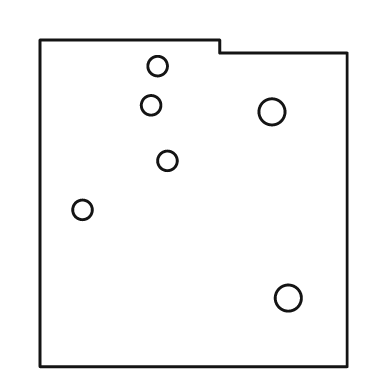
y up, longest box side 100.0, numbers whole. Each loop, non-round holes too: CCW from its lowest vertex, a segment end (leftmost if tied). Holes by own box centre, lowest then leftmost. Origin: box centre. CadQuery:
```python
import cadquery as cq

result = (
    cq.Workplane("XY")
    .moveTo(-47.0, -50.0)
    .lineTo(47.0, -50.0)
    .lineTo(47.0, 46.0)
    .lineTo(8.0, 46.0)
    .lineTo(8.0, 50.0)
    .lineTo(-47.0, 50.0)
    .close()
    .moveTo(29.0, -29.0)
    .circle(4.0)
    .moveTo(-34.0, -2.0)
    .circle(3.0)
    .moveTo(-8.0, 13.0)
    .circle(3.0)
    .moveTo(24.0, 28.0)
    .circle(4.0)
    .moveTo(-13.0, 30.0)
    .circle(3.0)
    .moveTo(-11.0, 42.0)
    .circle(3.0)
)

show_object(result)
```